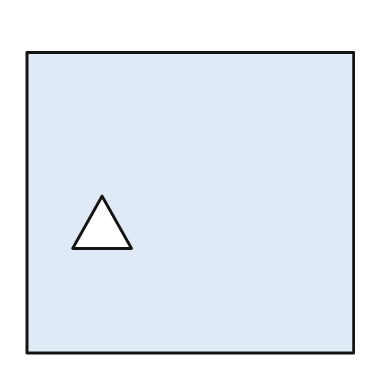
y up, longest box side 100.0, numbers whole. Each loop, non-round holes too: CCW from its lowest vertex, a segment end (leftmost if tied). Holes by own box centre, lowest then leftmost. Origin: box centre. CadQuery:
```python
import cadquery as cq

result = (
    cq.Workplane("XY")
    .moveTo(-50.0, -46.0)
    .lineTo(50.0, -46.0)
    .lineTo(50.0, 46.0)
    .lineTo(-50.0, 46.0)
    .close()
    .moveTo(-36.0, -14.0)
    .lineTo(-18.0, -14.0)
    .lineTo(-27.0, 2.0)
    .close()
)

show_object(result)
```